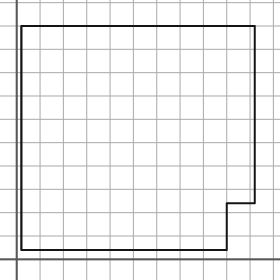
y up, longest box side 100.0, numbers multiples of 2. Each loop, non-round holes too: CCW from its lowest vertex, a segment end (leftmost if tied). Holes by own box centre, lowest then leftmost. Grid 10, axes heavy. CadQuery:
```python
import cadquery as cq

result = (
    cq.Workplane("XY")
    .moveTo(2.0, 4.0)
    .lineTo(90.0, 4.0)
    .lineTo(90.0, 24.0)
    .lineTo(102.0, 24.0)
    .lineTo(102.0, 100.0)
    .lineTo(2.0, 100.0)
    .close()
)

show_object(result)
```